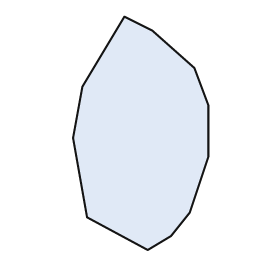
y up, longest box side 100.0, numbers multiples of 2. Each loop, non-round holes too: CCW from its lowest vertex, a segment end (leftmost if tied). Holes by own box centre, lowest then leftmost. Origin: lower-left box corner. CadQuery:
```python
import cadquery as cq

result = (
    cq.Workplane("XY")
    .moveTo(32.0, 0.0)
    .lineTo(42.0, 6.0)
    .lineTo(50.0, 16.0)
    .lineTo(58.0, 40.0)
    .lineTo(58.0, 62.0)
    .lineTo(52.0, 78.0)
    .lineTo(34.0, 94.0)
    .lineTo(22.0, 100.0)
    .lineTo(4.0, 70.0)
    .lineTo(0.0, 48.0)
    .lineTo(6.0, 14.0)
    .close()
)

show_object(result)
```